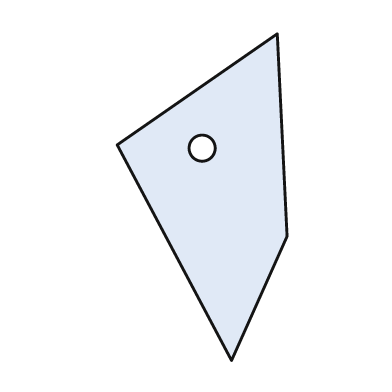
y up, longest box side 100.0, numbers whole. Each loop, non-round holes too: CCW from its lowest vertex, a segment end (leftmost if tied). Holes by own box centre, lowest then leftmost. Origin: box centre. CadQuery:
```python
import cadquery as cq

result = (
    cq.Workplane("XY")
    .moveTo(9.0, -50.0)
    .lineTo(26.0, -12.0)
    .lineTo(23.0, 50.0)
    .lineTo(-26.0, 16.0)
    .close()
    .moveTo(0.0, 15.0)
    .circle(4.0)
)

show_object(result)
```